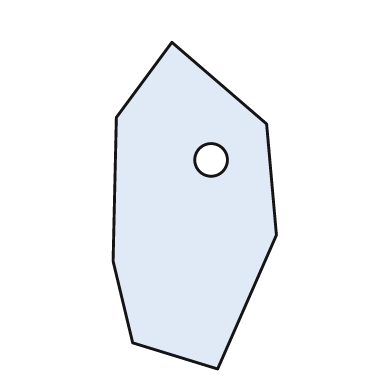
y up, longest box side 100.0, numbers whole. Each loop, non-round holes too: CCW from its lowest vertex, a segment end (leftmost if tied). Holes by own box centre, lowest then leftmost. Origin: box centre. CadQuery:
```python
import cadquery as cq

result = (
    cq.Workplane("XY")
    .moveTo(7.0, -50.0)
    .lineTo(25.0, -9.0)
    .lineTo(22.0, 25.0)
    .lineTo(-7.0, 50.0)
    .lineTo(-24.0, 27.0)
    .lineTo(-25.0, -17.0)
    .lineTo(-19.0, -42.0)
    .close()
    .moveTo(5.0, 14.0)
    .circle(5.0)
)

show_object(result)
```